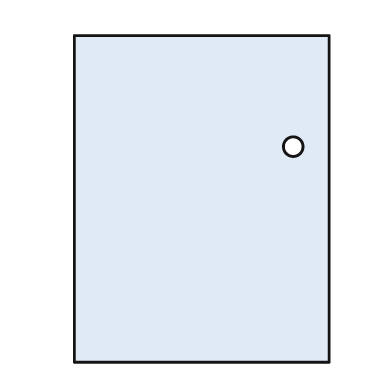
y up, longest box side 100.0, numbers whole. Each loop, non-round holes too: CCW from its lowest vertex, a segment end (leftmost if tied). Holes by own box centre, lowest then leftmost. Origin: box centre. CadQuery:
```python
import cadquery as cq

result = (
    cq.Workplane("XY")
    .moveTo(-39.0, -50.0)
    .lineTo(39.0, -50.0)
    .lineTo(39.0, 50.0)
    .lineTo(-39.0, 50.0)
    .close()
    .moveTo(28.0, 16.0)
    .circle(3.0)
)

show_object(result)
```